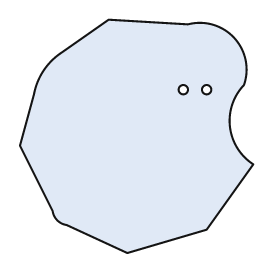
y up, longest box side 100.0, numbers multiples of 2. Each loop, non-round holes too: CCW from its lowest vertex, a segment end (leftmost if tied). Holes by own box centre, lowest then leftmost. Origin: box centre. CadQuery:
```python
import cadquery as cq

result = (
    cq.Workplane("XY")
    .moveTo(-4.0, -50.0)
    .lineTo(30.0, -40.0)
    .lineTo(50.0, -12.0)
    .threePointArc((40.0, 4.0), (46.0, 22.0))
    .threePointArc((42.0, 42.0), (22.0, 48.0))
    .lineTo(-12.0, 50.0)
    .lineTo(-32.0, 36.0)
    .threePointArc((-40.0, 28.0), (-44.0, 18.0))
    .lineTo(-50.0, -4.0)
    .lineTo(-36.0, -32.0)
    .threePointArc((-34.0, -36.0), (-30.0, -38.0))
    .close()
    .moveTo(20.0, 20.0)
    .circle(2.0)
    .moveTo(30.0, 20.0)
    .circle(2.0)
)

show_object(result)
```